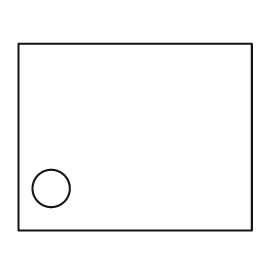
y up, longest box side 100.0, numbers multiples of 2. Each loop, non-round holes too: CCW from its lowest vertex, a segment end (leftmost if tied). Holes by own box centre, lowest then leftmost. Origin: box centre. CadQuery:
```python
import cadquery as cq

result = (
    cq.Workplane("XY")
    .moveTo(-50.0, -40.0)
    .lineTo(50.0, -40.0)
    .lineTo(50.0, 40.0)
    .lineTo(-50.0, 40.0)
    .close()
    .moveTo(-36.0, -22.0)
    .circle(8.0)
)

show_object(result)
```